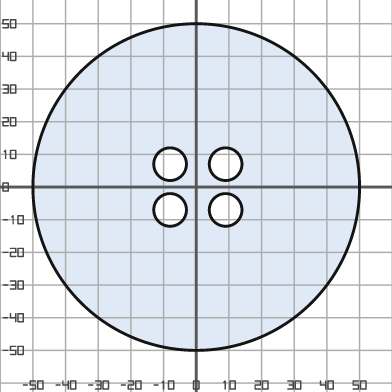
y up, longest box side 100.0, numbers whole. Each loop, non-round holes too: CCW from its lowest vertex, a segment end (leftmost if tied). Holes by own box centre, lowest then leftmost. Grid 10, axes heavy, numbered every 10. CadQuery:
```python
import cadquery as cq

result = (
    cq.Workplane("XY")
    .moveTo(0.0, 0.0)
    .circle(50.0)
    .moveTo(-8.0, -7.0)
    .circle(5.0)
    .moveTo(9.0, -7.0)
    .circle(5.0)
    .moveTo(-8.0, 7.0)
    .circle(5.0)
    .moveTo(9.0, 7.0)
    .circle(5.0)
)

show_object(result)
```